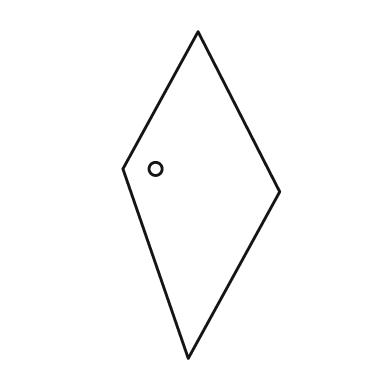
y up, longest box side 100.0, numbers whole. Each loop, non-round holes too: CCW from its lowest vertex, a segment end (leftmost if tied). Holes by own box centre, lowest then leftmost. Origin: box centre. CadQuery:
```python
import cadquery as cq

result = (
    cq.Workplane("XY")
    .moveTo(-4.0, -50.0)
    .lineTo(24.0, 1.0)
    .lineTo(-1.0, 50.0)
    .lineTo(-24.0, 8.0)
    .close()
    .moveTo(-14.0, 8.0)
    .circle(2.0)
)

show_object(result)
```